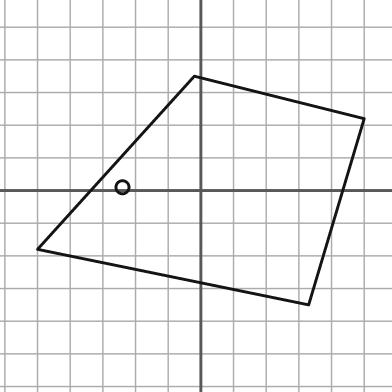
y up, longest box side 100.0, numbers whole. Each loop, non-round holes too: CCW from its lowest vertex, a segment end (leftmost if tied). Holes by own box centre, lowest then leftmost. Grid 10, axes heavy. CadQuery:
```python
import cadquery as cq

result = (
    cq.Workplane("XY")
    .moveTo(33.0, -35.0)
    .lineTo(50.0, 22.0)
    .lineTo(-2.0, 35.0)
    .lineTo(-50.0, -18.0)
    .close()
    .moveTo(-24.0, 1.0)
    .circle(2.0)
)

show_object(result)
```